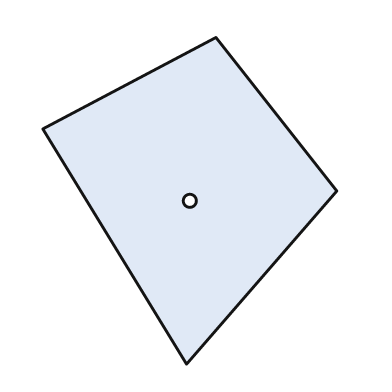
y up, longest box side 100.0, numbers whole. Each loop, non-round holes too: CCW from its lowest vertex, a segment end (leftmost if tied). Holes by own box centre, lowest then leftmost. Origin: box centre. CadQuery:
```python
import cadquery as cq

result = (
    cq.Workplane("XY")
    .moveTo(-1.0, -50.0)
    .lineTo(45.0, 3.0)
    .lineTo(8.0, 50.0)
    .lineTo(-45.0, 22.0)
    .close()
    .moveTo(0.0, 0.0)
    .circle(2.0)
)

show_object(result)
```